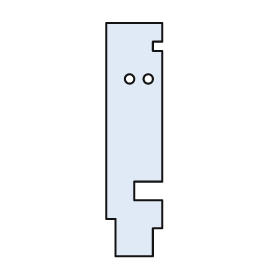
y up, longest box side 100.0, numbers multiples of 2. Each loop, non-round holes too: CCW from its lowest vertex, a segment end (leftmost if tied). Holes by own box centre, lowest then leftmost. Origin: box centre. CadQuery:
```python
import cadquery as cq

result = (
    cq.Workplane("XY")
    .moveTo(-8.0, -50.0)
    .lineTo(8.0, -50.0)
    .lineTo(8.0, -38.0)
    .lineTo(12.0, -38.0)
    .lineTo(12.0, -26.0)
    .lineTo(0.0, -26.0)
    .lineTo(0.0, -18.0)
    .lineTo(12.0, -18.0)
    .lineTo(12.0, 38.0)
    .lineTo(8.0, 38.0)
    .lineTo(8.0, 42.0)
    .lineTo(12.0, 42.0)
    .lineTo(12.0, 50.0)
    .lineTo(-12.0, 50.0)
    .lineTo(-12.0, -34.0)
    .lineTo(-8.0, -34.0)
    .close()
    .moveTo(-2.0, 26.0)
    .circle(2.0)
    .moveTo(6.0, 26.0)
    .circle(2.0)
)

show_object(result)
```